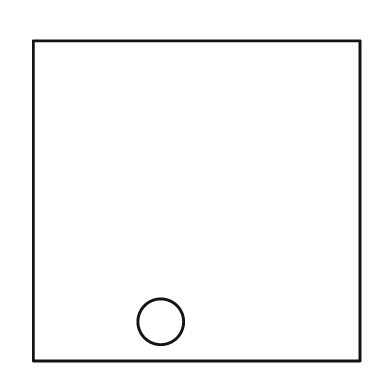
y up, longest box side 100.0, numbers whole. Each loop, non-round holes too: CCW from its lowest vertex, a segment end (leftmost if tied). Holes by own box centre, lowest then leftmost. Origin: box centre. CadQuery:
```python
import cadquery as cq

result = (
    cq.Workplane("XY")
    .moveTo(-50.0, -49.0)
    .lineTo(50.0, -49.0)
    .lineTo(50.0, 49.0)
    .lineTo(-50.0, 49.0)
    .close()
    .moveTo(-11.0, -37.0)
    .circle(7.0)
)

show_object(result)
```